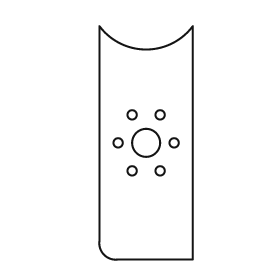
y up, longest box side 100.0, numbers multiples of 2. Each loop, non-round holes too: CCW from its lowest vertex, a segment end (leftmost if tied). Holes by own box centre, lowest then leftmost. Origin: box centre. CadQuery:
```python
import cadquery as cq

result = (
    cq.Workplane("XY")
    .moveTo(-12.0, -50.0)
    .lineTo(20.0, -50.0)
    .lineTo(20.0, 50.0)
    .threePointArc((0.0, 40.0), (-20.0, 50.0))
    .lineTo(-20.0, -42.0)
    .threePointArc((-18.0, -48.0), (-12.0, -50.0))
    .close()
    .moveTo(-6.0, -12.0)
    .circle(2.0)
    .moveTo(6.0, -12.0)
    .circle(2.0)
    .moveTo(-12.0, 0.0)
    .circle(2.0)
    .moveTo(0.0, 0.0)
    .circle(6.0)
    .moveTo(12.0, 0.0)
    .circle(2.0)
    .moveTo(-6.0, 12.0)
    .circle(2.0)
    .moveTo(6.0, 12.0)
    .circle(2.0)
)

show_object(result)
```